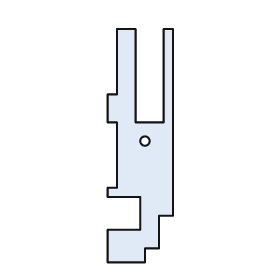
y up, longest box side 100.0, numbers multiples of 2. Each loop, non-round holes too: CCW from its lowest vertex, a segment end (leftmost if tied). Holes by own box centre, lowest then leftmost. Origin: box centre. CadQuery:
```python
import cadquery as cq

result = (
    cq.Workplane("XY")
    .moveTo(-14.0, -50.0)
    .lineTo(2.0, -50.0)
    .lineTo(2.0, -44.0)
    .lineTo(8.0, -44.0)
    .lineTo(8.0, -30.0)
    .lineTo(14.0, -30.0)
    .lineTo(14.0, 50.0)
    .lineTo(10.0, 50.0)
    .lineTo(10.0, 10.0)
    .lineTo(-2.0, 10.0)
    .lineTo(-2.0, 50.0)
    .lineTo(-10.0, 50.0)
    .lineTo(-10.0, 22.0)
    .lineTo(-14.0, 22.0)
    .lineTo(-14.0, 10.0)
    .lineTo(-10.0, 10.0)
    .lineTo(-10.0, -18.0)
    .lineTo(-14.0, -18.0)
    .lineTo(-14.0, -22.0)
    .lineTo(0.0, -22.0)
    .lineTo(0.0, -36.0)
    .lineTo(-14.0, -36.0)
    .close()
    .moveTo(2.0, 2.0)
    .circle(2.0)
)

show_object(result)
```